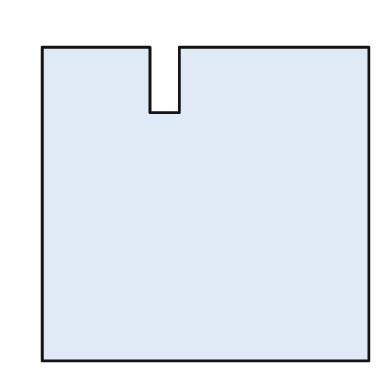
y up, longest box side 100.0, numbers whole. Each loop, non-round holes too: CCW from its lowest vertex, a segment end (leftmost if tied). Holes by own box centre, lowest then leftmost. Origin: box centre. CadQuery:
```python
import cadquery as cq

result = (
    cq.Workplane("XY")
    .moveTo(-50.0, -48.0)
    .lineTo(50.0, -48.0)
    .lineTo(50.0, 48.0)
    .lineTo(-8.0, 48.0)
    .lineTo(-8.0, 28.0)
    .lineTo(-17.0, 28.0)
    .lineTo(-17.0, 48.0)
    .lineTo(-50.0, 48.0)
    .close()
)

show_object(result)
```